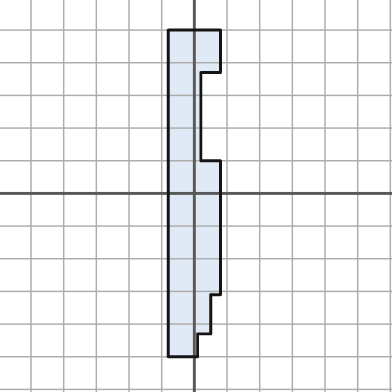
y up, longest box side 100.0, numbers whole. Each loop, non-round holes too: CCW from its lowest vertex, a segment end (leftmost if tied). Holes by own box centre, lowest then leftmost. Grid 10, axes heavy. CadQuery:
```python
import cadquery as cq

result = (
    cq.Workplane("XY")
    .moveTo(-8.0, -50.0)
    .lineTo(1.0, -50.0)
    .lineTo(1.0, -43.0)
    .lineTo(5.0, -43.0)
    .lineTo(5.0, -31.0)
    .lineTo(8.0, -31.0)
    .lineTo(8.0, 10.0)
    .lineTo(2.0, 10.0)
    .lineTo(2.0, 37.0)
    .lineTo(8.0, 37.0)
    .lineTo(8.0, 50.0)
    .lineTo(-8.0, 50.0)
    .close()
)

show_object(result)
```